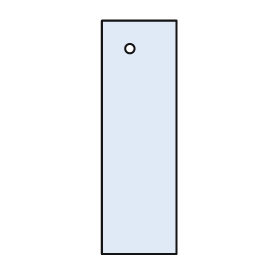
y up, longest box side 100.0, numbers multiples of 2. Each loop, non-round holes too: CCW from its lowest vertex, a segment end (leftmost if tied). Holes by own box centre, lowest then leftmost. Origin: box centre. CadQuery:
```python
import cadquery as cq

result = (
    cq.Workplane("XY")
    .moveTo(-16.0, -50.0)
    .lineTo(16.0, -50.0)
    .lineTo(16.0, 50.0)
    .lineTo(-16.0, 50.0)
    .close()
    .moveTo(-4.0, 38.0)
    .circle(2.0)
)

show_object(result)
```